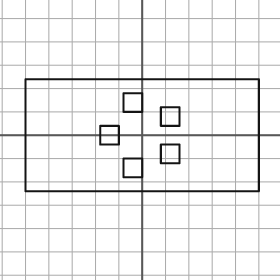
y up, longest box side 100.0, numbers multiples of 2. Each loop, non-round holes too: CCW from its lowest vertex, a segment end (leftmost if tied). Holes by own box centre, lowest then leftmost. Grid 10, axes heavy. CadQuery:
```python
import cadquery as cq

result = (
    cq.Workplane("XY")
    .moveTo(-50.0, -24.0)
    .lineTo(50.0, -24.0)
    .lineTo(50.0, 24.0)
    .lineTo(-50.0, 24.0)
    .close()
    .moveTo(-8.0, -18.0)
    .lineTo(0.0, -18.0)
    .lineTo(0.0, -10.0)
    .lineTo(-8.0, -10.0)
    .close()
    .moveTo(8.0, -12.0)
    .lineTo(16.0, -12.0)
    .lineTo(16.0, -4.0)
    .lineTo(8.0, -4.0)
    .close()
    .moveTo(-18.0, -4.0)
    .lineTo(-10.0, -4.0)
    .lineTo(-10.0, 4.0)
    .lineTo(-18.0, 4.0)
    .close()
    .moveTo(8.0, 4.0)
    .lineTo(16.0, 4.0)
    .lineTo(16.0, 12.0)
    .lineTo(8.0, 12.0)
    .close()
    .moveTo(-8.0, 10.0)
    .lineTo(0.0, 10.0)
    .lineTo(0.0, 18.0)
    .lineTo(-8.0, 18.0)
    .close()
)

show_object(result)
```